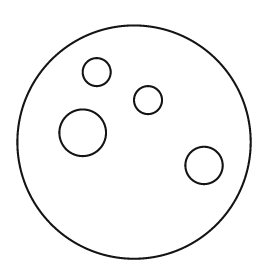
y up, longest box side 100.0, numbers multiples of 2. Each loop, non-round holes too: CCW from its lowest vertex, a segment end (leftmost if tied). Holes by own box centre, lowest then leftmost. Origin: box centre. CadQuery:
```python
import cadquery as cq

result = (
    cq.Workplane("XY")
    .moveTo(0.0, 0.0)
    .circle(50.0)
    .moveTo(30.0, -10.0)
    .circle(8.0)
    .moveTo(-22.0, 4.0)
    .circle(10.0)
    .moveTo(6.0, 18.0)
    .circle(6.0)
    .moveTo(-16.0, 30.0)
    .circle(6.0)
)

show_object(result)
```